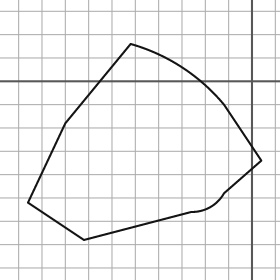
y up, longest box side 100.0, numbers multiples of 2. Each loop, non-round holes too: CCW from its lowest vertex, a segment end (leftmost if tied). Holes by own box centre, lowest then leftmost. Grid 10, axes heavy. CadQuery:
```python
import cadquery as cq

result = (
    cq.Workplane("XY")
    .moveTo(-72.0, -68.0)
    .lineTo(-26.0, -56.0)
    .threePointArc((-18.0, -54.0), (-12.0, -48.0))
    .lineTo(4.0, -34.0)
    .lineTo(-12.0, -10.0)
    .threePointArc((-30.0, 6.0), (-52.0, 16.0))
    .lineTo(-80.0, -18.0)
    .lineTo(-96.0, -52.0)
    .close()
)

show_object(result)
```